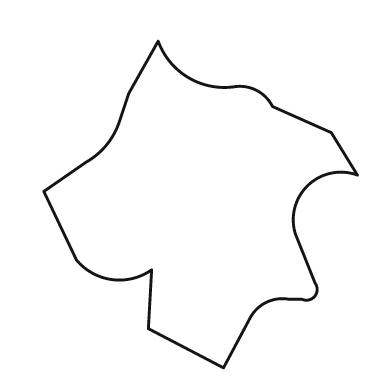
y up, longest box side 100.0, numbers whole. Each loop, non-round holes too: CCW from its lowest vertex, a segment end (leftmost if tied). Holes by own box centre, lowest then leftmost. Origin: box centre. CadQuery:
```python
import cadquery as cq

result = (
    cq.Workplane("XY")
    .moveTo(7.0, -50.0)
    .lineTo(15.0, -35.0)
    .threePointArc((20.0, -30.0), (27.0, -29.0))
    .lineTo(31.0, -29.0)
    .threePointArc((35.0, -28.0), (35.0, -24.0))
    .lineTo(29.0, -9.0)
    .threePointArc((33.0, 6.0), (48.0, 9.0))
    .lineTo(40.0, 22.0)
    .lineTo(22.0, 30.0)
    .threePointArc((17.0, 35.0), (10.0, 36.0))
    .threePointArc((-4.0, 39.0), (-13.0, 50.0))
    .lineTo(-22.0, 34.0)
    .lineTo(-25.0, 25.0)
    .threePointArc((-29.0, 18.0), (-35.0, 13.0))
    .lineTo(-48.0, 4.0)
    .lineTo(-38.0, -17.0)
    .threePointArc((-27.0, -23.0), (-15.0, -20.0))
    .lineTo(-16.0, -38.0)
    .close()
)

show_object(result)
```